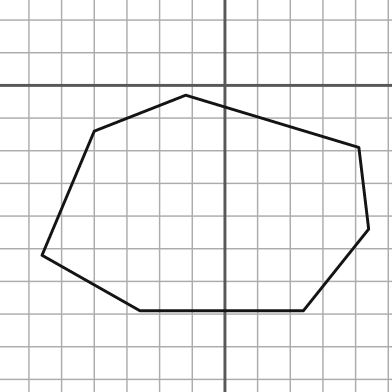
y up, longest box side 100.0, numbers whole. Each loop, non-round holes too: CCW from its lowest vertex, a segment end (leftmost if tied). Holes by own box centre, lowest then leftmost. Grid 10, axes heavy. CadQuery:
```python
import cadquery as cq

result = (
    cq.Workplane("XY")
    .moveTo(-26.0, -69.0)
    .lineTo(24.0, -69.0)
    .lineTo(44.0, -44.0)
    .lineTo(41.0, -19.0)
    .lineTo(-12.0, -3.0)
    .lineTo(-40.0, -14.0)
    .lineTo(-56.0, -52.0)
    .close()
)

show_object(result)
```